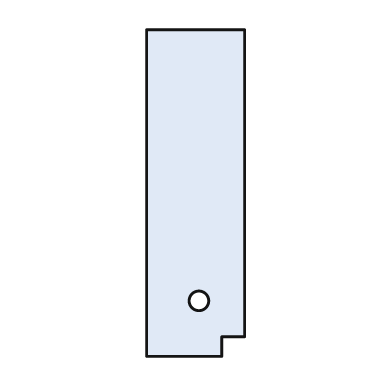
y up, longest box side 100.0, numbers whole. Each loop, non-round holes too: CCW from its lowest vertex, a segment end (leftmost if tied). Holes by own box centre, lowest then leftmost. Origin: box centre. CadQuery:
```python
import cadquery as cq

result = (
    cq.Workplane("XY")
    .moveTo(-15.0, -50.0)
    .lineTo(8.0, -50.0)
    .lineTo(8.0, -44.0)
    .lineTo(15.0, -44.0)
    .lineTo(15.0, 50.0)
    .lineTo(-15.0, 50.0)
    .close()
    .moveTo(1.0, -33.0)
    .circle(3.0)
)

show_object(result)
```